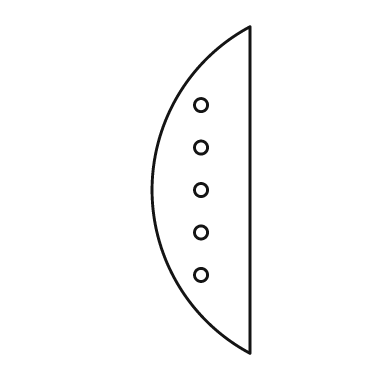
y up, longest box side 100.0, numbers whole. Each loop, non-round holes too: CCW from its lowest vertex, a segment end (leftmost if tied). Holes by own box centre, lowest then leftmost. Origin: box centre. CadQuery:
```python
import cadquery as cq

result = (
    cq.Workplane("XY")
    .moveTo(15.0, -50.0)
    .lineTo(15.0, 50.0)
    .threePointArc((-15.0, 0.0), (15.0, -50.0))
    .close()
    .moveTo(0.0, -26.0)
    .circle(2.0)
    .moveTo(0.0, -13.0)
    .circle(2.0)
    .moveTo(0.0, 0.0)
    .circle(2.0)
    .moveTo(0.0, 13.0)
    .circle(2.0)
    .moveTo(0.0, 26.0)
    .circle(2.0)
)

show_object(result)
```